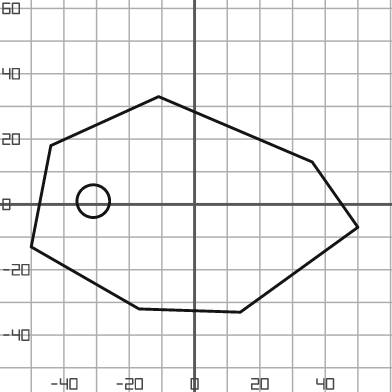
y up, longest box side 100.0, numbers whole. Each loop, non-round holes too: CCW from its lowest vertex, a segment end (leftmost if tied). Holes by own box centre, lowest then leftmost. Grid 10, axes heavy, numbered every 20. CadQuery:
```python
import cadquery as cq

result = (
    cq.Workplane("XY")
    .moveTo(14.0, -33.0)
    .lineTo(50.0, -7.0)
    .lineTo(36.0, 13.0)
    .lineTo(-11.0, 33.0)
    .lineTo(-44.0, 18.0)
    .lineTo(-50.0, -13.0)
    .lineTo(-17.0, -32.0)
    .close()
    .moveTo(-31.0, 1.0)
    .circle(5.0)
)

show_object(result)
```